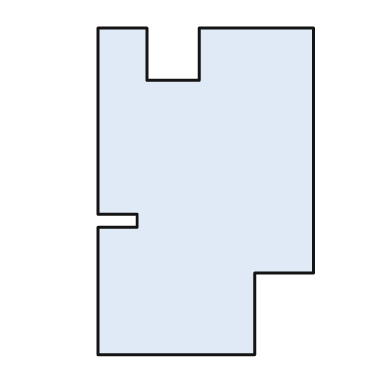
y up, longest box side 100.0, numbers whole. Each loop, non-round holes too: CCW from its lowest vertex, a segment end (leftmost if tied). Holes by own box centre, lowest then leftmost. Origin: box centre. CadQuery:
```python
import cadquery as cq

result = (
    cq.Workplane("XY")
    .moveTo(-33.0, -50.0)
    .lineTo(15.0, -50.0)
    .lineTo(15.0, -25.0)
    .lineTo(33.0, -25.0)
    .lineTo(33.0, 50.0)
    .lineTo(-2.0, 50.0)
    .lineTo(-2.0, 34.0)
    .lineTo(-18.0, 34.0)
    .lineTo(-18.0, 50.0)
    .lineTo(-33.0, 50.0)
    .lineTo(-33.0, -7.0)
    .lineTo(-21.0, -7.0)
    .lineTo(-21.0, -11.0)
    .lineTo(-33.0, -11.0)
    .close()
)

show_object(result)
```